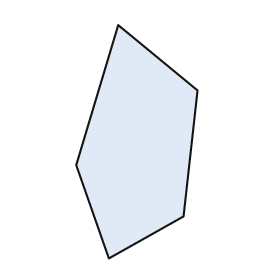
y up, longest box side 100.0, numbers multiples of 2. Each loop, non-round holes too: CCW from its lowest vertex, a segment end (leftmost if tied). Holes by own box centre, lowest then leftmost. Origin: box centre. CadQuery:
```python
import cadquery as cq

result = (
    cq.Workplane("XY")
    .moveTo(-12.0, -50.0)
    .lineTo(20.0, -32.0)
    .lineTo(26.0, 22.0)
    .lineTo(-8.0, 50.0)
    .lineTo(-26.0, -10.0)
    .close()
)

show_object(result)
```